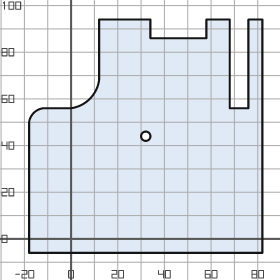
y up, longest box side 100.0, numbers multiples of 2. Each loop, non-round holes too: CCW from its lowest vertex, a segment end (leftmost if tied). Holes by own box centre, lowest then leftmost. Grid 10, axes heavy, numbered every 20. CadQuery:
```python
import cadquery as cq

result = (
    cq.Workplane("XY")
    .moveTo(-18.0, -6.0)
    .lineTo(82.0, -6.0)
    .lineTo(82.0, 94.0)
    .lineTo(76.0, 94.0)
    .lineTo(76.0, 56.0)
    .lineTo(68.0, 56.0)
    .lineTo(68.0, 94.0)
    .lineTo(58.0, 94.0)
    .lineTo(58.0, 86.0)
    .lineTo(34.0, 86.0)
    .lineTo(34.0, 94.0)
    .lineTo(12.0, 94.0)
    .lineTo(12.0, 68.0)
    .threePointArc((8.0, 60.0), (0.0, 56.0))
    .lineTo(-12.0, 56.0)
    .threePointArc((-16.0, 54.0), (-18.0, 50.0))
    .close()
    .moveTo(32.0, 44.0)
    .circle(2.0)
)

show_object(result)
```